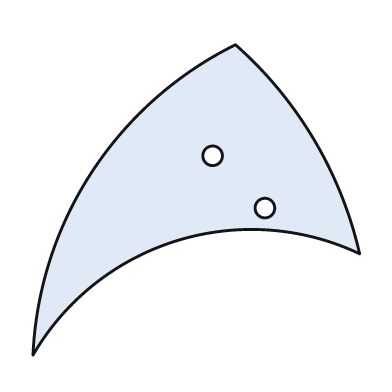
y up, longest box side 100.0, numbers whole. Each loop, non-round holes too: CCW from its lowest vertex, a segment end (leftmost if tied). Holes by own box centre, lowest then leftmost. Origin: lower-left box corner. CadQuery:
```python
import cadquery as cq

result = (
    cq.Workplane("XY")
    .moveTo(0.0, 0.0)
    .threePointArc((44.0, 35.0), (100.0, 31.0))
    .threePointArc((86.0, 66.0), (62.0, 95.0))
    .threePointArc((18.0, 56.0), (0.0, 0.0))
    .close()
    .moveTo(71.0, 45.0)
    .circle(3.0)
    .moveTo(55.0, 61.0)
    .circle(3.0)
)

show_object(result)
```